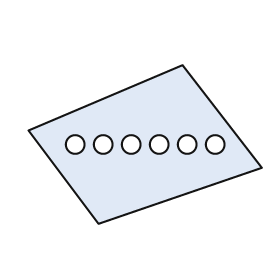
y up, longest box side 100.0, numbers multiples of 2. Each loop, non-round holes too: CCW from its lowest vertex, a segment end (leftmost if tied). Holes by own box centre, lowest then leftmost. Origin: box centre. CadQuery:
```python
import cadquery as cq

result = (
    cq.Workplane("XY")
    .moveTo(-20.0, -34.0)
    .lineTo(50.0, -10.0)
    .lineTo(16.0, 34.0)
    .lineTo(-50.0, 6.0)
    .close()
    .moveTo(-30.0, 0.0)
    .circle(4.0)
    .moveTo(-18.0, 0.0)
    .circle(4.0)
    .moveTo(-6.0, 0.0)
    .circle(4.0)
    .moveTo(6.0, 0.0)
    .circle(4.0)
    .moveTo(18.0, 0.0)
    .circle(4.0)
    .moveTo(30.0, 0.0)
    .circle(4.0)
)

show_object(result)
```